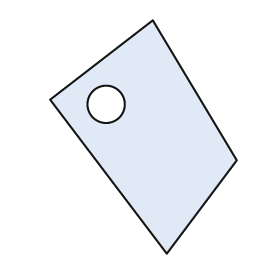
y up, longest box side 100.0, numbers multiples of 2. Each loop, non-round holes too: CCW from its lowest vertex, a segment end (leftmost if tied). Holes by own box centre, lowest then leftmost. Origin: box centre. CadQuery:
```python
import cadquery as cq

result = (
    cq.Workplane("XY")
    .moveTo(10.0, -50.0)
    .lineTo(40.0, -10.0)
    .lineTo(4.0, 50.0)
    .lineTo(-40.0, 16.0)
    .close()
    .moveTo(-16.0, 14.0)
    .circle(8.0)
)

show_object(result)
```